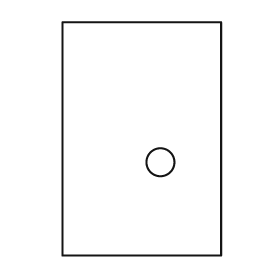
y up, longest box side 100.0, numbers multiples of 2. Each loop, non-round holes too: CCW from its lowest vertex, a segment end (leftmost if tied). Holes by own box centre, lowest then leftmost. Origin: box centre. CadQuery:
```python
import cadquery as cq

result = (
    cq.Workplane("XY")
    .moveTo(-34.0, -50.0)
    .lineTo(34.0, -50.0)
    .lineTo(34.0, 50.0)
    .lineTo(-34.0, 50.0)
    .close()
    .moveTo(8.0, -10.0)
    .circle(6.0)
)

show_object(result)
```